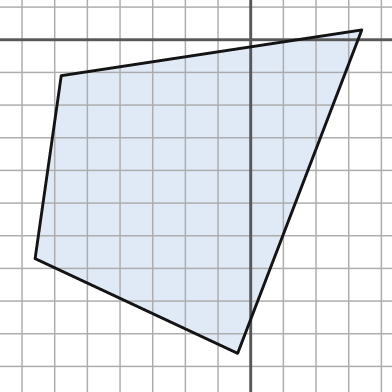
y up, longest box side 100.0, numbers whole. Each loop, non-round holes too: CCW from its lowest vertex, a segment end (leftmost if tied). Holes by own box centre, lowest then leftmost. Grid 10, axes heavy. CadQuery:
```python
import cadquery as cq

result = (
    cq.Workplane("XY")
    .moveTo(-4.0, -96.0)
    .lineTo(34.0, 3.0)
    .lineTo(-58.0, -11.0)
    .lineTo(-66.0, -67.0)
    .close()
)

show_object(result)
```